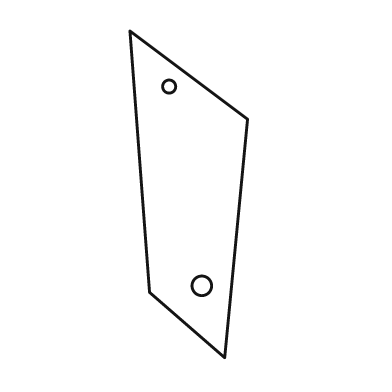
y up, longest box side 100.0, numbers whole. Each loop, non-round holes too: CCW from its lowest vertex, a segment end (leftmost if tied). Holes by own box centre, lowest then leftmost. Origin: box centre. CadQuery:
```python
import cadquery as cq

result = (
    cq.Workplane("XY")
    .moveTo(11.0, -50.0)
    .lineTo(18.0, 23.0)
    .lineTo(-18.0, 50.0)
    .lineTo(-12.0, -30.0)
    .close()
    .moveTo(4.0, -28.0)
    .circle(3.0)
    .moveTo(-6.0, 33.0)
    .circle(2.0)
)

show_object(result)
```